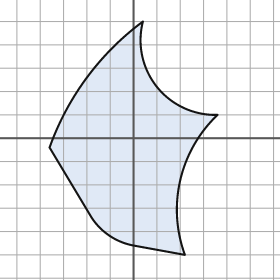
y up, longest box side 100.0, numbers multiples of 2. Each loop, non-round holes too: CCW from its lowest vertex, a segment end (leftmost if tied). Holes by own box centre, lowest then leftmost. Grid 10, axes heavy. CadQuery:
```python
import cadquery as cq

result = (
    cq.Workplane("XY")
    .moveTo(22.0, -50.0)
    .threePointArc((20.0, -18.0), (36.0, 10.0))
    .threePointArc((10.0, 22.0), (4.0, 50.0))
    .threePointArc((-20.0, 26.0), (-36.0, -4.0))
    .lineTo(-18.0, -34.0)
    .threePointArc((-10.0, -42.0), (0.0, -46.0))
    .close()
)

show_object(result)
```